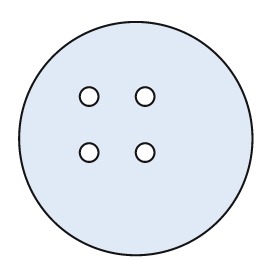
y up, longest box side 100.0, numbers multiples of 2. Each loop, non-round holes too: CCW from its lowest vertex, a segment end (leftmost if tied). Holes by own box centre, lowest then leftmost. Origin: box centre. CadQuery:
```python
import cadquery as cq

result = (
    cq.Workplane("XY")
    .moveTo(0.0, 0.0)
    .circle(50.0)
    .moveTo(-20.0, -6.0)
    .circle(4.0)
    .moveTo(4.0, -6.0)
    .circle(4.0)
    .moveTo(-20.0, 18.0)
    .circle(4.0)
    .moveTo(4.0, 18.0)
    .circle(4.0)
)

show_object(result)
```